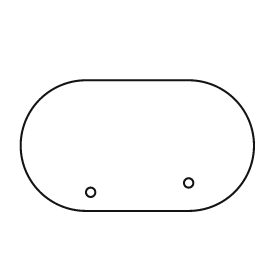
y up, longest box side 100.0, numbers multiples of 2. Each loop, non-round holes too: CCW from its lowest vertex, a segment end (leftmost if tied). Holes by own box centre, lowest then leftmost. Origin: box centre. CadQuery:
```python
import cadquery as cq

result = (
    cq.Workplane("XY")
    .moveTo(-22.0, -28.0)
    .lineTo(22.0, -28.0)
    .threePointArc((50.0, 0.0), (22.0, 28.0))
    .lineTo(-22.0, 28.0)
    .threePointArc((-50.0, 0.0), (-22.0, -28.0))
    .close()
    .moveTo(-20.0, -20.0)
    .circle(2.0)
    .moveTo(22.0, -16.0)
    .circle(2.0)
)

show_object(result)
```